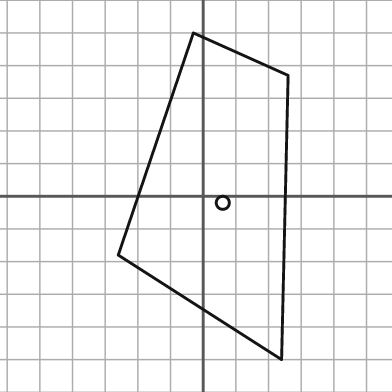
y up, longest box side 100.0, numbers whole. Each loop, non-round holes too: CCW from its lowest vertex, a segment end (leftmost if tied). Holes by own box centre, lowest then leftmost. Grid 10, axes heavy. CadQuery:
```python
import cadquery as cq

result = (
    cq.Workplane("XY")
    .moveTo(24.0, -50.0)
    .lineTo(26.0, 37.0)
    .lineTo(-3.0, 50.0)
    .lineTo(-26.0, -18.0)
    .close()
    .moveTo(6.0, -2.0)
    .circle(2.0)
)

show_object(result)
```